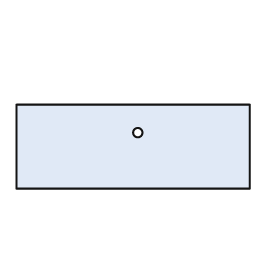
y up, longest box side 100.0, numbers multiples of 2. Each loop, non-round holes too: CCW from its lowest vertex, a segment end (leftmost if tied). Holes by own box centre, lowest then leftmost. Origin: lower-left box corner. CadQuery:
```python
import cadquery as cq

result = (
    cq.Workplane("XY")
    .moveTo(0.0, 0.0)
    .lineTo(100.0, 0.0)
    .lineTo(100.0, 36.0)
    .lineTo(0.0, 36.0)
    .close()
    .moveTo(52.0, 24.0)
    .circle(2.0)
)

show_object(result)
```